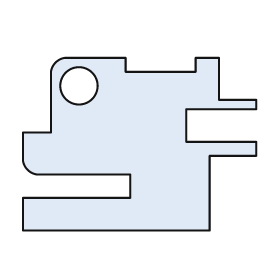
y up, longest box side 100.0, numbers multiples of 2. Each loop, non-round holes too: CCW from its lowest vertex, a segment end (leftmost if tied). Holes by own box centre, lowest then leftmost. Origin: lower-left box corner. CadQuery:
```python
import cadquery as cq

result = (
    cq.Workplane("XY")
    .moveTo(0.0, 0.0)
    .lineTo(80.0, 0.0)
    .lineTo(80.0, 32.0)
    .lineTo(100.0, 32.0)
    .lineTo(100.0, 38.0)
    .lineTo(70.0, 38.0)
    .lineTo(70.0, 52.0)
    .lineTo(100.0, 52.0)
    .lineTo(100.0, 56.0)
    .lineTo(84.0, 56.0)
    .lineTo(84.0, 74.0)
    .lineTo(74.0, 74.0)
    .lineTo(74.0, 68.0)
    .lineTo(44.0, 68.0)
    .lineTo(44.0, 74.0)
    .lineTo(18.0, 74.0)
    .threePointArc((14.0, 72.0), (12.0, 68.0))
    .lineTo(12.0, 42.0)
    .lineTo(0.0, 42.0)
    .lineTo(0.0, 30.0)
    .threePointArc((2.0, 26.0), (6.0, 24.0))
    .lineTo(46.0, 24.0)
    .lineTo(46.0, 14.0)
    .lineTo(0.0, 14.0)
    .close()
    .moveTo(24.0, 62.0)
    .circle(8.0)
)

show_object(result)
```